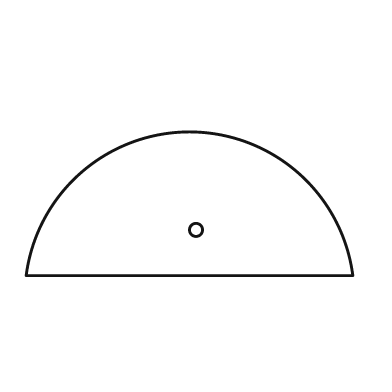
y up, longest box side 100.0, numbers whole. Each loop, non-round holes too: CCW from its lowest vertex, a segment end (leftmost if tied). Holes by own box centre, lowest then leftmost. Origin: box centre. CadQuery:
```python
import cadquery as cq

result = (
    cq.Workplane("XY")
    .moveTo(-50.0, -22.0)
    .lineTo(50.0, -22.0)
    .threePointArc((0.0, 22.0), (-50.0, -22.0))
    .close()
    .moveTo(2.0, -8.0)
    .circle(2.0)
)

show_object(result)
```